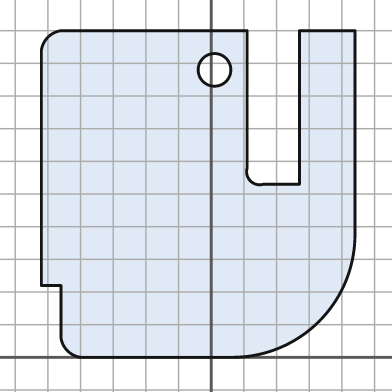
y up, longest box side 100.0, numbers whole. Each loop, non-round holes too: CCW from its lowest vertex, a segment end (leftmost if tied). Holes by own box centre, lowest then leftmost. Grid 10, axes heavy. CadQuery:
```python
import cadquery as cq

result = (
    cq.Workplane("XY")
    .moveTo(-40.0, 0.0)
    .lineTo(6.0, 0.0)
    .threePointArc((33.0, 11.0), (44.0, 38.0))
    .lineTo(44.0, 100.0)
    .lineTo(27.0, 100.0)
    .lineTo(27.0, 53.0)
    .lineTo(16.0, 53.0)
    .threePointArc((12.0, 54.0), (11.0, 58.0))
    .lineTo(11.0, 100.0)
    .lineTo(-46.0, 100.0)
    .threePointArc((-50.0, 98.0), (-52.0, 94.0))
    .lineTo(-52.0, 22.0)
    .lineTo(-46.0, 22.0)
    .lineTo(-46.0, 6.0)
    .threePointArc((-44.0, 2.0), (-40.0, 0.0))
    .close()
    .moveTo(1.0, 88.0)
    .circle(5.0)
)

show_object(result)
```